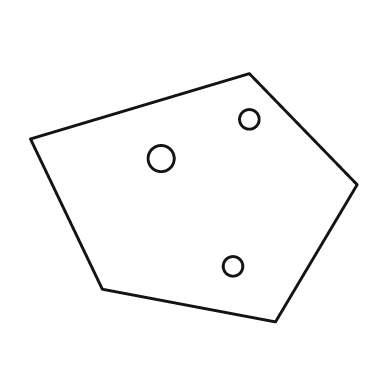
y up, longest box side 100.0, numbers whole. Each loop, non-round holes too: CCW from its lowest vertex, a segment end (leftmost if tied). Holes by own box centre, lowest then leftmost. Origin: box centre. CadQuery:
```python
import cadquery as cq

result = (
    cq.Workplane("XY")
    .moveTo(25.0, -38.0)
    .lineTo(50.0, 4.0)
    .lineTo(17.0, 38.0)
    .lineTo(-50.0, 18.0)
    .lineTo(-28.0, -28.0)
    .close()
    .moveTo(12.0, -21.0)
    .circle(3.0)
    .moveTo(-10.0, 12.0)
    .circle(4.0)
    .moveTo(17.0, 24.0)
    .circle(3.0)
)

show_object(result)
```